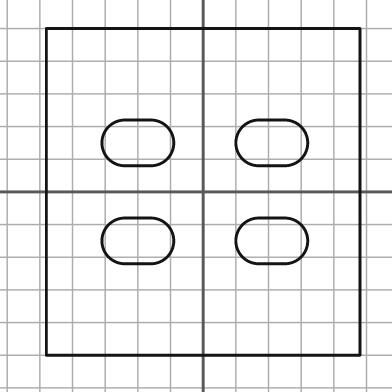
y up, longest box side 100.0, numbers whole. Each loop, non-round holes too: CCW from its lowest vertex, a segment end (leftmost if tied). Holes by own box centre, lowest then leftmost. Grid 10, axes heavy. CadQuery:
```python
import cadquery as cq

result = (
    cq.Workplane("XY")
    .moveTo(-48.0, -50.0)
    .lineTo(48.0, -50.0)
    .lineTo(48.0, 50.0)
    .lineTo(-48.0, 50.0)
    .close()
    .moveTo(-24.0, -22.0)
    .lineTo(-16.0, -22.0)
    .threePointArc((-9.0, -15.0), (-16.0, -8.0))
    .lineTo(-24.0, -8.0)
    .threePointArc((-31.0, -15.0), (-24.0, -22.0))
    .close()
    .moveTo(17.0, -22.0)
    .lineTo(25.0, -22.0)
    .threePointArc((32.0, -15.0), (25.0, -8.0))
    .lineTo(17.0, -8.0)
    .threePointArc((10.0, -15.0), (17.0, -22.0))
    .close()
    .moveTo(-24.0, 8.0)
    .lineTo(-16.0, 8.0)
    .threePointArc((-9.0, 15.0), (-16.0, 22.0))
    .lineTo(-24.0, 22.0)
    .threePointArc((-31.0, 15.0), (-24.0, 8.0))
    .close()
    .moveTo(17.0, 8.0)
    .lineTo(25.0, 8.0)
    .threePointArc((32.0, 15.0), (25.0, 22.0))
    .lineTo(17.0, 22.0)
    .threePointArc((10.0, 15.0), (17.0, 8.0))
    .close()
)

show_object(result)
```